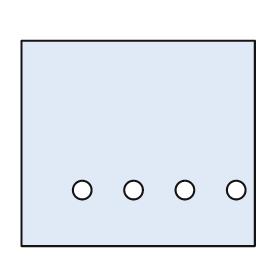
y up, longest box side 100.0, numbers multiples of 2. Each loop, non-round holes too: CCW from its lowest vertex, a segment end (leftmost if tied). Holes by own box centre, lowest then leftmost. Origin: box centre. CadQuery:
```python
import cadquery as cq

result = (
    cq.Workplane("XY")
    .moveTo(-50.0, -44.0)
    .lineTo(50.0, -44.0)
    .lineTo(50.0, 44.0)
    .lineTo(-50.0, 44.0)
    .close()
    .moveTo(-24.0, -20.0)
    .circle(4.0)
    .moveTo(-2.0, -20.0)
    .circle(4.0)
    .moveTo(20.0, -20.0)
    .circle(4.0)
    .moveTo(42.0, -20.0)
    .circle(4.0)
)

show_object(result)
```